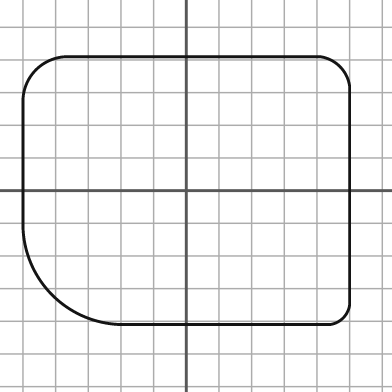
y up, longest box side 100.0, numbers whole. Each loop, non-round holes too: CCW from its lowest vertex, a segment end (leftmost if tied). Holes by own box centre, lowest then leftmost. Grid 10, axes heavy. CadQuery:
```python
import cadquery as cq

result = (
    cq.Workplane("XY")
    .moveTo(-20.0, -41.0)
    .lineTo(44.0, -41.0)
    .threePointArc((48.0, -39.0), (50.0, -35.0))
    .lineTo(50.0, 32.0)
    .threePointArc((47.0, 38.0), (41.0, 41.0))
    .lineTo(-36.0, 41.0)
    .threePointArc((-46.0, 37.0), (-50.0, 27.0))
    .lineTo(-50.0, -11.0)
    .threePointArc((-41.0, -32.0), (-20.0, -41.0))
    .close()
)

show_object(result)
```